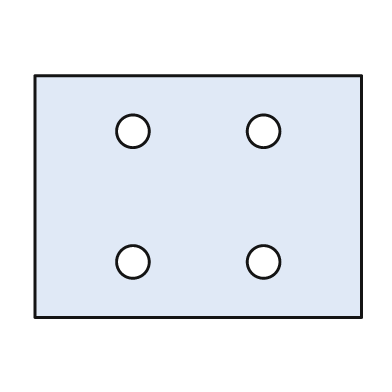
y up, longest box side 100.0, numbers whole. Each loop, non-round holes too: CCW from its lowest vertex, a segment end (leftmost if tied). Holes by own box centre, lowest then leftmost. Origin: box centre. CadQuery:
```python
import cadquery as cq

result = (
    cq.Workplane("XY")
    .moveTo(-50.0, -37.0)
    .lineTo(50.0, -37.0)
    .lineTo(50.0, 37.0)
    .lineTo(-50.0, 37.0)
    .close()
    .moveTo(-20.0, -20.0)
    .circle(5.0)
    .moveTo(20.0, -20.0)
    .circle(5.0)
    .moveTo(-20.0, 20.0)
    .circle(5.0)
    .moveTo(20.0, 20.0)
    .circle(5.0)
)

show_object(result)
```